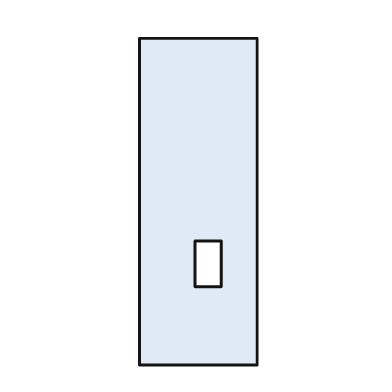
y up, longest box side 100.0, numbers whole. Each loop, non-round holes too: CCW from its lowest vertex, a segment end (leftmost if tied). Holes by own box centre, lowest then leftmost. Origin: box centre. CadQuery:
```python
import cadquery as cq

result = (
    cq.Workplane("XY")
    .moveTo(-18.0, -50.0)
    .lineTo(18.0, -50.0)
    .lineTo(18.0, 50.0)
    .lineTo(-18.0, 50.0)
    .close()
    .moveTo(-1.0, -26.0)
    .lineTo(7.0, -26.0)
    .lineTo(7.0, -12.0)
    .lineTo(-1.0, -12.0)
    .close()
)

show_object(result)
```